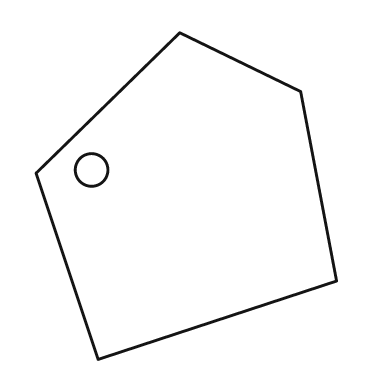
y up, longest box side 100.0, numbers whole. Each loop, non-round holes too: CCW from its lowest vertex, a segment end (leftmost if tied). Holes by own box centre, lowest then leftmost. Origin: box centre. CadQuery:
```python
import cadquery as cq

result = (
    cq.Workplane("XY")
    .moveTo(-27.0, -50.0)
    .lineTo(46.0, -26.0)
    .lineTo(35.0, 32.0)
    .lineTo(-2.0, 50.0)
    .lineTo(-46.0, 7.0)
    .close()
    .moveTo(-29.0, 8.0)
    .circle(5.0)
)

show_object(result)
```